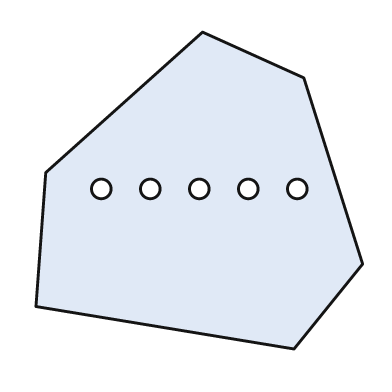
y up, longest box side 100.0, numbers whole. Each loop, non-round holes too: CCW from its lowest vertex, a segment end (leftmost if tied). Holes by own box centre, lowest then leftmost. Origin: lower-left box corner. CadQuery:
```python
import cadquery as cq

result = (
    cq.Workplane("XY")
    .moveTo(79.0, 0.0)
    .lineTo(100.0, 26.0)
    .lineTo(82.0, 83.0)
    .lineTo(51.0, 97.0)
    .lineTo(3.0, 54.0)
    .lineTo(0.0, 13.0)
    .close()
    .moveTo(20.0, 49.0)
    .circle(3.0)
    .moveTo(35.0, 49.0)
    .circle(3.0)
    .moveTo(50.0, 49.0)
    .circle(3.0)
    .moveTo(65.0, 49.0)
    .circle(3.0)
    .moveTo(80.0, 49.0)
    .circle(3.0)
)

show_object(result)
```